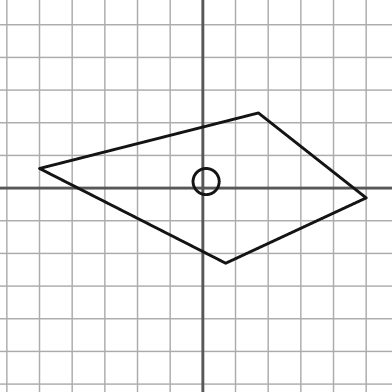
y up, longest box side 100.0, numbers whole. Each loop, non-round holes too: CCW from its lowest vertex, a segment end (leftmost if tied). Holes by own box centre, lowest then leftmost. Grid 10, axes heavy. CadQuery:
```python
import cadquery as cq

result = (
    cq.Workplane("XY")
    .moveTo(7.0, -23.0)
    .lineTo(50.0, -3.0)
    .lineTo(17.0, 23.0)
    .lineTo(-50.0, 6.0)
    .close()
    .moveTo(1.0, 2.0)
    .circle(4.0)
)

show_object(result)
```